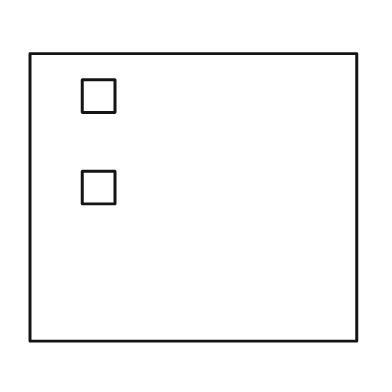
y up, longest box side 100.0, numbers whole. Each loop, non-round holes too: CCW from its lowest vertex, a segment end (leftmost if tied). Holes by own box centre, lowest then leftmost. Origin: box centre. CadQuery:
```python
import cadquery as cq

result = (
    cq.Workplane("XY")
    .moveTo(-50.0, -44.0)
    .lineTo(50.0, -44.0)
    .lineTo(50.0, 44.0)
    .lineTo(-50.0, 44.0)
    .close()
    .moveTo(-34.0, -2.0)
    .lineTo(-24.0, -2.0)
    .lineTo(-24.0, 8.0)
    .lineTo(-34.0, 8.0)
    .close()
    .moveTo(-34.0, 26.0)
    .lineTo(-24.0, 26.0)
    .lineTo(-24.0, 36.0)
    .lineTo(-34.0, 36.0)
    .close()
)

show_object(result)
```